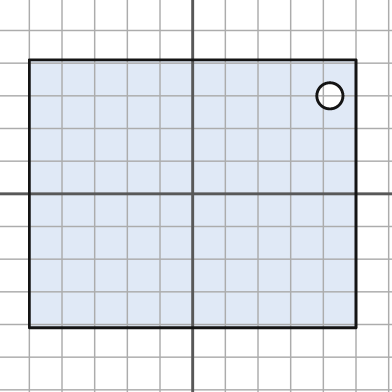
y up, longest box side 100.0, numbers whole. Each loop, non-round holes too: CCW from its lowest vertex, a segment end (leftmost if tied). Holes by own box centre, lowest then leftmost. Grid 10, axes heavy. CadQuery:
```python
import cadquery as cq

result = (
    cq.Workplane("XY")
    .moveTo(-50.0, -41.0)
    .lineTo(50.0, -41.0)
    .lineTo(50.0, 41.0)
    .lineTo(-50.0, 41.0)
    .close()
    .moveTo(42.0, 30.0)
    .circle(4.0)
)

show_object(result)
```